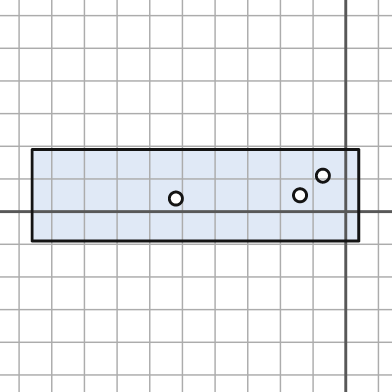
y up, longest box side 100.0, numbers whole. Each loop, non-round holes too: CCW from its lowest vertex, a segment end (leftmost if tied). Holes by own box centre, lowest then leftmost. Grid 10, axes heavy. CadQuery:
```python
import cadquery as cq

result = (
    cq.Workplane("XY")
    .moveTo(-96.0, -9.0)
    .lineTo(4.0, -9.0)
    .lineTo(4.0, 19.0)
    .lineTo(-96.0, 19.0)
    .close()
    .moveTo(-52.0, 4.0)
    .circle(2.0)
    .moveTo(-14.0, 5.0)
    .circle(2.0)
    .moveTo(-7.0, 11.0)
    .circle(2.0)
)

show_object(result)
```